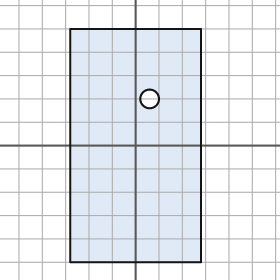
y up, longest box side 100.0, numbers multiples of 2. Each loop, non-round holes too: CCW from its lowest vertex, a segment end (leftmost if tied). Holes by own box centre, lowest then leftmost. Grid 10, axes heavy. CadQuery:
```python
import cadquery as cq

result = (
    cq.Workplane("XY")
    .moveTo(-28.0, -50.0)
    .lineTo(28.0, -50.0)
    .lineTo(28.0, 50.0)
    .lineTo(-28.0, 50.0)
    .close()
    .moveTo(6.0, 20.0)
    .circle(4.0)
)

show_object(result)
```